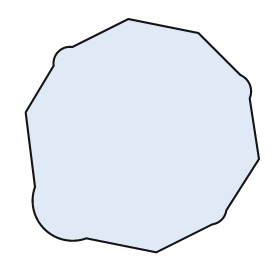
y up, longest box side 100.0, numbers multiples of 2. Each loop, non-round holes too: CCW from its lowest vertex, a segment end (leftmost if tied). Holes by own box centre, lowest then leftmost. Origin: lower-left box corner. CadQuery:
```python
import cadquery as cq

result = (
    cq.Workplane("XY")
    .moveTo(56.0, 0.0)
    .lineTo(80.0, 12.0)
    .threePointArc((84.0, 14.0), (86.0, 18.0))
    .lineTo(100.0, 40.0)
    .lineTo(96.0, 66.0)
    .threePointArc((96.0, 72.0), (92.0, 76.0))
    .lineTo(74.0, 94.0)
    .lineTo(44.0, 100.0)
    .lineTo(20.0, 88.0)
    .threePointArc((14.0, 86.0), (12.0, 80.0))
    .lineTo(0.0, 60.0)
    .lineTo(4.0, 28.0)
    .threePointArc((8.0, 10.0), (26.0, 6.0))
    .close()
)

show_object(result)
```